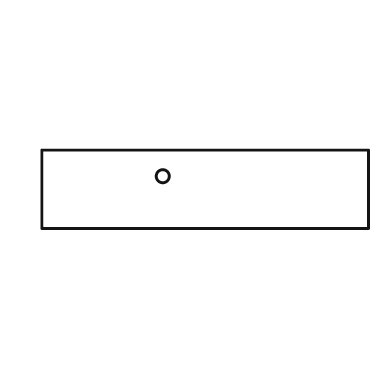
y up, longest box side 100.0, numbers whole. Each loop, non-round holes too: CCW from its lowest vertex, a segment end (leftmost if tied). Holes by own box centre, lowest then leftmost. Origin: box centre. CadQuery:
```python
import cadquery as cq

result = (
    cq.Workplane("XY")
    .moveTo(-50.0, -12.0)
    .lineTo(50.0, -12.0)
    .lineTo(50.0, 12.0)
    .lineTo(-50.0, 12.0)
    .close()
    .moveTo(-13.0, 4.0)
    .circle(2.0)
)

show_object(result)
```